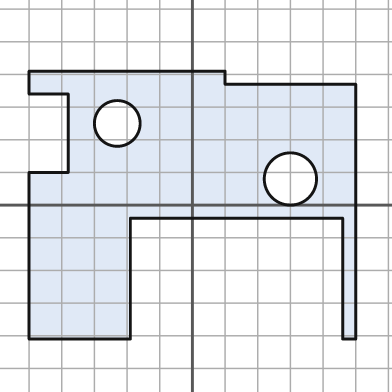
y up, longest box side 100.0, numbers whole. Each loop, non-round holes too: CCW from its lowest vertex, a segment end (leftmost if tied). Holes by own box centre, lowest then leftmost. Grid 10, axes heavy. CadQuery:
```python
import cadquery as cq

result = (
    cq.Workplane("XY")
    .moveTo(-50.0, -41.0)
    .lineTo(-19.0, -41.0)
    .lineTo(-19.0, -4.0)
    .lineTo(46.0, -4.0)
    .lineTo(46.0, -41.0)
    .lineTo(50.0, -41.0)
    .lineTo(50.0, 37.0)
    .lineTo(10.0, 37.0)
    .lineTo(10.0, 41.0)
    .lineTo(-50.0, 41.0)
    .lineTo(-50.0, 34.0)
    .lineTo(-38.0, 34.0)
    .lineTo(-38.0, 10.0)
    .lineTo(-50.0, 10.0)
    .close()
    .moveTo(30.0, 8.0)
    .circle(8.0)
    .moveTo(-23.0, 25.0)
    .circle(7.0)
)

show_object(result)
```